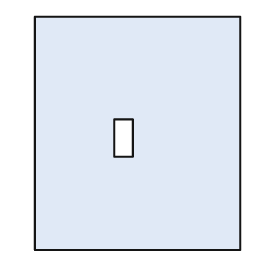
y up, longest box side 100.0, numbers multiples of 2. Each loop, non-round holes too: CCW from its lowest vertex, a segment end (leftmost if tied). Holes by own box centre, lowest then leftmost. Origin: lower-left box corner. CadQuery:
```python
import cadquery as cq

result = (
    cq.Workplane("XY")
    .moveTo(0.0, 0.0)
    .lineTo(88.0, 0.0)
    .lineTo(88.0, 100.0)
    .lineTo(0.0, 100.0)
    .close()
    .moveTo(34.0, 40.0)
    .lineTo(42.0, 40.0)
    .lineTo(42.0, 56.0)
    .lineTo(34.0, 56.0)
    .close()
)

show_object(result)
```